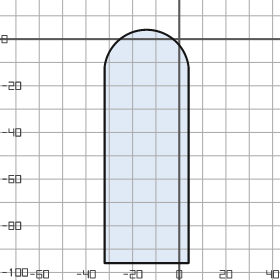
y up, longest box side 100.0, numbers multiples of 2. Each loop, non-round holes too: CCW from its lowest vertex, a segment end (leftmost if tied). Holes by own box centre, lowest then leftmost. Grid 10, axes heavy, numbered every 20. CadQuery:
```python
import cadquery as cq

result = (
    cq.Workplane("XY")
    .moveTo(-32.0, -96.0)
    .lineTo(4.0, -96.0)
    .lineTo(4.0, -12.0)
    .threePointArc((-14.0, 4.0), (-32.0, -12.0))
    .close()
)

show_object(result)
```